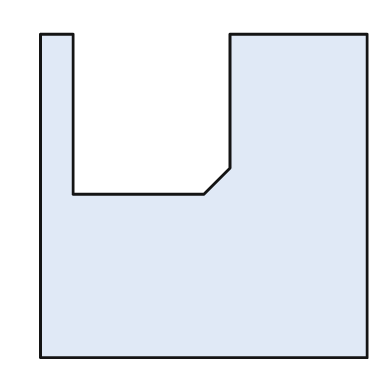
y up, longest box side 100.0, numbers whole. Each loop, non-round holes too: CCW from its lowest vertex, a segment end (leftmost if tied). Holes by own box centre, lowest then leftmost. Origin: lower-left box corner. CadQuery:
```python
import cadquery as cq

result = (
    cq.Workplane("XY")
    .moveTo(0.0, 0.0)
    .lineTo(100.0, 0.0)
    .lineTo(100.0, 99.0)
    .lineTo(58.0, 99.0)
    .lineTo(58.0, 58.0)
    .lineTo(50.0, 50.0)
    .lineTo(10.0, 50.0)
    .lineTo(10.0, 99.0)
    .lineTo(0.0, 99.0)
    .close()
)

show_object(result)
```